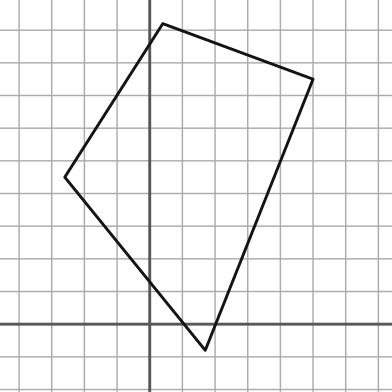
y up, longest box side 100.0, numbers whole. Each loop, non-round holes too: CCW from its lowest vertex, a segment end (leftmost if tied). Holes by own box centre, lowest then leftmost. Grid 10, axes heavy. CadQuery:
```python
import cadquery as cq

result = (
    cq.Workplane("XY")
    .moveTo(17.0, -8.0)
    .lineTo(50.0, 75.0)
    .lineTo(4.0, 92.0)
    .lineTo(-26.0, 45.0)
    .close()
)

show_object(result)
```